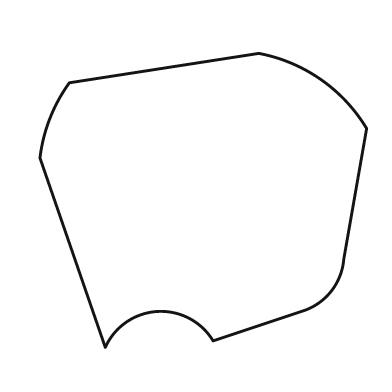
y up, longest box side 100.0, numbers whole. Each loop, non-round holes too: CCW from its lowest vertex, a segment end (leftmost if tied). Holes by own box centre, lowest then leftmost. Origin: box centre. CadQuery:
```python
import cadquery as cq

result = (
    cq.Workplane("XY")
    .moveTo(-30.0, -45.0)
    .threePointArc((-14.0, -34.0), (3.0, -43.0))
    .lineTo(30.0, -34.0)
    .threePointArc((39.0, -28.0), (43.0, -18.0))
    .lineTo(50.0, 22.0)
    .threePointArc((36.0, 37.0), (17.0, 45.0))
    .lineTo(-41.0, 36.0)
    .threePointArc((-47.0, 25.0), (-50.0, 13.0))
    .close()
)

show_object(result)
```